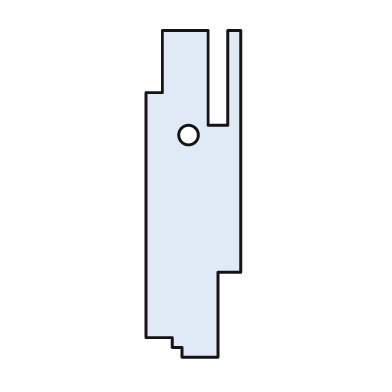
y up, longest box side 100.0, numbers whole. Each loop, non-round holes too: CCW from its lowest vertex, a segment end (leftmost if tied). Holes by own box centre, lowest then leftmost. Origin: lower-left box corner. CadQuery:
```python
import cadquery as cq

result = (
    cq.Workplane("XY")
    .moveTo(11.0, 0.0)
    .lineTo(22.0, 0.0)
    .lineTo(22.0, 26.0)
    .lineTo(29.0, 26.0)
    .lineTo(29.0, 100.0)
    .lineTo(25.0, 100.0)
    .lineTo(25.0, 71.0)
    .lineTo(19.0, 71.0)
    .lineTo(19.0, 100.0)
    .lineTo(5.0, 100.0)
    .lineTo(5.0, 81.0)
    .lineTo(0.0, 81.0)
    .lineTo(0.0, 6.0)
    .lineTo(8.0, 6.0)
    .lineTo(8.0, 3.0)
    .lineTo(11.0, 3.0)
    .close()
    .moveTo(13.0, 68.0)
    .circle(3.0)
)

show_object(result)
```